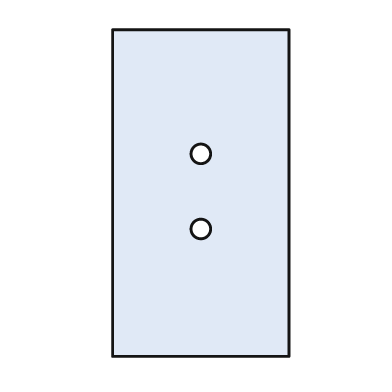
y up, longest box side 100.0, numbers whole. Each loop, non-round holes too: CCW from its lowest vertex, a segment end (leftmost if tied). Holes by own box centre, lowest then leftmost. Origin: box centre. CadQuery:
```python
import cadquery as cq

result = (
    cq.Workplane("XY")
    .moveTo(-27.0, -50.0)
    .lineTo(27.0, -50.0)
    .lineTo(27.0, 50.0)
    .lineTo(-27.0, 50.0)
    .close()
    .moveTo(0.0, -11.0)
    .circle(3.0)
    .moveTo(0.0, 12.0)
    .circle(3.0)
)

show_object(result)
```